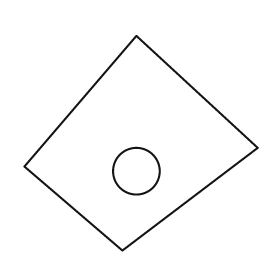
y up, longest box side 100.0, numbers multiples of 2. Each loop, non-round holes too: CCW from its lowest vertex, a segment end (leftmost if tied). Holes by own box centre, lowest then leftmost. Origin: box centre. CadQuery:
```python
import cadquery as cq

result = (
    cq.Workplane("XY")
    .moveTo(-8.0, -46.0)
    .lineTo(50.0, -2.0)
    .lineTo(-2.0, 46.0)
    .lineTo(-50.0, -10.0)
    .close()
    .moveTo(-2.0, -12.0)
    .circle(10.0)
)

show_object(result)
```